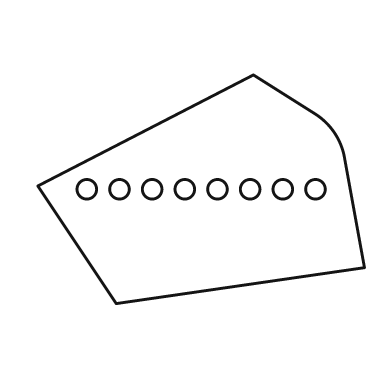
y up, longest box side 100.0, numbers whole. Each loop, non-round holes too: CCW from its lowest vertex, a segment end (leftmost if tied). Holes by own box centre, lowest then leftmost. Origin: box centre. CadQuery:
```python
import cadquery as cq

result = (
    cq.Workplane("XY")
    .moveTo(-26.0, -35.0)
    .lineTo(50.0, -24.0)
    .lineTo(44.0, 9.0)
    .threePointArc((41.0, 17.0), (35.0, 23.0))
    .lineTo(16.0, 35.0)
    .lineTo(-50.0, 1.0)
    .close()
    .moveTo(-35.0, 0.0)
    .circle(3.0)
    .moveTo(-25.0, 0.0)
    .circle(3.0)
    .moveTo(-15.0, 0.0)
    .circle(3.0)
    .moveTo(-5.0, 0.0)
    .circle(3.0)
    .moveTo(5.0, 0.0)
    .circle(3.0)
    .moveTo(15.0, 0.0)
    .circle(3.0)
    .moveTo(25.0, 0.0)
    .circle(3.0)
    .moveTo(35.0, 0.0)
    .circle(3.0)
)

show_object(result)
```